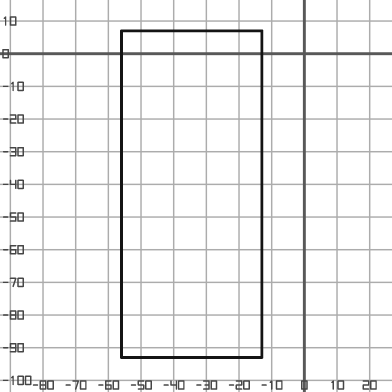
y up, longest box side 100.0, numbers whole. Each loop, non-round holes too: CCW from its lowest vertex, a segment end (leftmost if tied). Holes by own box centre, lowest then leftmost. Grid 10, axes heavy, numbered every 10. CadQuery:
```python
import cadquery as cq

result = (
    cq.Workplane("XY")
    .moveTo(-56.0, -93.0)
    .lineTo(-13.0, -93.0)
    .lineTo(-13.0, 7.0)
    .lineTo(-56.0, 7.0)
    .close()
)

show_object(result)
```